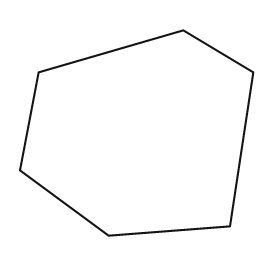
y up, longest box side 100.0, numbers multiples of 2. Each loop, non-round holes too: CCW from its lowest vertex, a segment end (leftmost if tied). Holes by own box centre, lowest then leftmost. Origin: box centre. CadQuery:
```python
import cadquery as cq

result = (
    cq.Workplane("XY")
    .moveTo(-12.0, -44.0)
    .lineTo(40.0, -40.0)
    .lineTo(50.0, 26.0)
    .lineTo(20.0, 44.0)
    .lineTo(-42.0, 26.0)
    .lineTo(-50.0, -16.0)
    .close()
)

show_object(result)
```